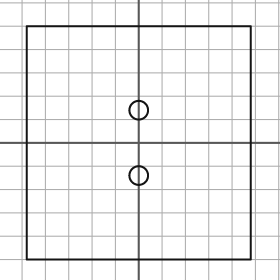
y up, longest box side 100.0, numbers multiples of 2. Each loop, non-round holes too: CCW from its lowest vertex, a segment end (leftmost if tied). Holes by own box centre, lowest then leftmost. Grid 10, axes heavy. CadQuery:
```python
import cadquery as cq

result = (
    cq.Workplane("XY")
    .moveTo(-48.0, -50.0)
    .lineTo(48.0, -50.0)
    .lineTo(48.0, 50.0)
    .lineTo(-48.0, 50.0)
    .close()
    .moveTo(0.0, -14.0)
    .circle(4.0)
    .moveTo(0.0, 14.0)
    .circle(4.0)
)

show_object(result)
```